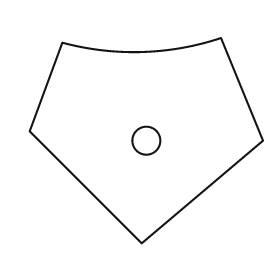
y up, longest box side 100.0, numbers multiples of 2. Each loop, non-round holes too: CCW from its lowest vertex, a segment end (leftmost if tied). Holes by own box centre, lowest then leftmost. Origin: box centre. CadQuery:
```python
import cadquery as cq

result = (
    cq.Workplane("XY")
    .moveTo(-2.0, -44.0)
    .lineTo(50.0, 0.0)
    .lineTo(32.0, 44.0)
    .threePointArc((-2.0, 38.0), (-36.0, 42.0))
    .lineTo(-50.0, 4.0)
    .close()
    .moveTo(0.0, 0.0)
    .circle(6.0)
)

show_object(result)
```